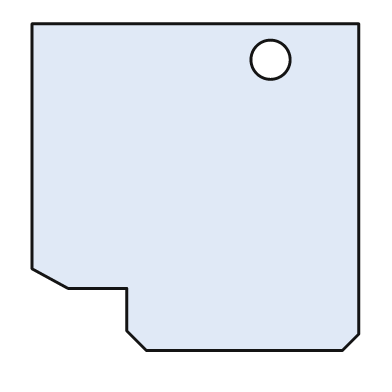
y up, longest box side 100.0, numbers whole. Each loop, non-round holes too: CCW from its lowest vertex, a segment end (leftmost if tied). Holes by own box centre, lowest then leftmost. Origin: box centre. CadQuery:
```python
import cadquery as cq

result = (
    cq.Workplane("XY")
    .moveTo(-15.0, -50.0)
    .lineTo(45.0, -50.0)
    .lineTo(50.0, -45.0)
    .lineTo(50.0, 50.0)
    .lineTo(-50.0, 50.0)
    .lineTo(-50.0, -25.0)
    .lineTo(-39.0, -31.0)
    .lineTo(-21.0, -31.0)
    .lineTo(-21.0, -44.0)
    .close()
    .moveTo(23.0, 39.0)
    .circle(6.0)
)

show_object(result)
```